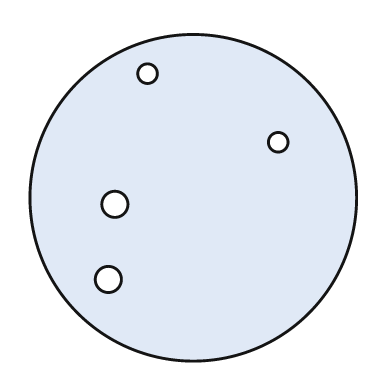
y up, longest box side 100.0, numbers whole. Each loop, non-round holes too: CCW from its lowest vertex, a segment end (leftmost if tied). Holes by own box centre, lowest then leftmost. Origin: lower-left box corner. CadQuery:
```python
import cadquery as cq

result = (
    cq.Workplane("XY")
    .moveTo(50.0, 50.0)
    .circle(50.0)
    .moveTo(24.0, 25.0)
    .circle(4.0)
    .moveTo(26.0, 48.0)
    .circle(4.0)
    .moveTo(76.0, 67.0)
    .circle(3.0)
    .moveTo(36.0, 88.0)
    .circle(3.0)
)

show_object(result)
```